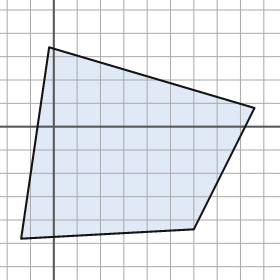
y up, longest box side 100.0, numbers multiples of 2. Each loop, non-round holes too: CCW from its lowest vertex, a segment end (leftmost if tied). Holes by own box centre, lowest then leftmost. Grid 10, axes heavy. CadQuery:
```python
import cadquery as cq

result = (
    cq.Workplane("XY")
    .moveTo(-14.0, -48.0)
    .lineTo(60.0, -44.0)
    .lineTo(86.0, 8.0)
    .lineTo(-2.0, 34.0)
    .close()
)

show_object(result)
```